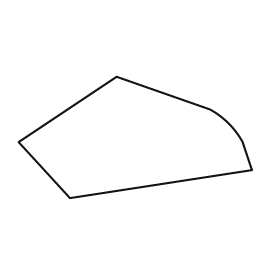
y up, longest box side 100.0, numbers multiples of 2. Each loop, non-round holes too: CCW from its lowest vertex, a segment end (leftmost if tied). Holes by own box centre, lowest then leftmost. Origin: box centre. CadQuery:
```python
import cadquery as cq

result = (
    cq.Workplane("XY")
    .moveTo(-28.0, -26.0)
    .lineTo(50.0, -14.0)
    .lineTo(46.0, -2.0)
    .threePointArc((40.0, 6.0), (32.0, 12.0))
    .lineTo(-8.0, 26.0)
    .lineTo(-50.0, -2.0)
    .close()
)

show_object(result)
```